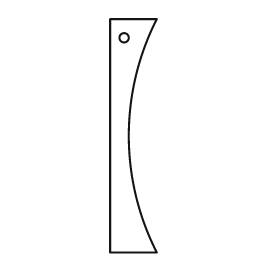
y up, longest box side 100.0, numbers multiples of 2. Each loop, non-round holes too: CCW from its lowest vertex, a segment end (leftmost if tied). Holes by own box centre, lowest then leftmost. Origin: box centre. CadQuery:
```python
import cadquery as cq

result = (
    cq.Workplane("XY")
    .moveTo(-10.0, -50.0)
    .lineTo(10.0, -50.0)
    .threePointArc((-2.0, 0.0), (10.0, 50.0))
    .lineTo(-10.0, 50.0)
    .close()
    .moveTo(-4.0, 42.0)
    .circle(2.0)
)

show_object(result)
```